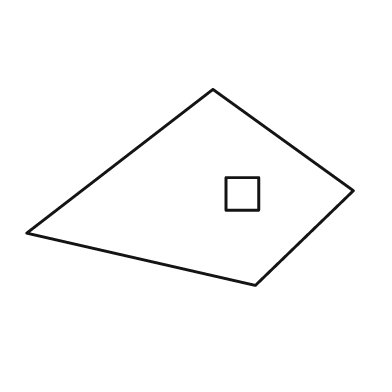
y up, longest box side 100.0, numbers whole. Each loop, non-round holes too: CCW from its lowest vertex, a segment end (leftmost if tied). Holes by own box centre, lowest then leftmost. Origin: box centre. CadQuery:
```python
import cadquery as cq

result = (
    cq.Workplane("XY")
    .moveTo(20.0, -30.0)
    .lineTo(50.0, -1.0)
    .lineTo(7.0, 30.0)
    .lineTo(-50.0, -14.0)
    .close()
    .moveTo(11.0, -7.0)
    .lineTo(21.0, -7.0)
    .lineTo(21.0, 3.0)
    .lineTo(11.0, 3.0)
    .close()
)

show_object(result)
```